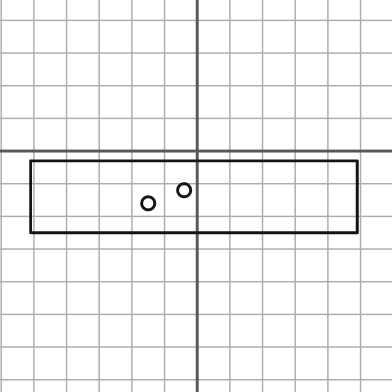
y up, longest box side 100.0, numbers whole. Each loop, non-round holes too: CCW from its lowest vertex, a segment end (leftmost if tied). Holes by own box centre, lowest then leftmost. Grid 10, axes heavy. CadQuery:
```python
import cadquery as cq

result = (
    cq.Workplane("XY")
    .moveTo(-51.0, -25.0)
    .lineTo(49.0, -25.0)
    .lineTo(49.0, -3.0)
    .lineTo(-51.0, -3.0)
    .close()
    .moveTo(-15.0, -16.0)
    .circle(2.0)
    .moveTo(-4.0, -12.0)
    .circle(2.0)
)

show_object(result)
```